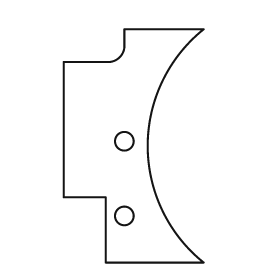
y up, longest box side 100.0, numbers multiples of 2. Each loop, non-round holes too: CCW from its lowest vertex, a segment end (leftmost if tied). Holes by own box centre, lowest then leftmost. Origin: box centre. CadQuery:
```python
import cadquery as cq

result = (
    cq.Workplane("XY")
    .moveTo(-12.0, -50.0)
    .lineTo(30.0, -50.0)
    .threePointArc((6.0, 0.0), (30.0, 50.0))
    .lineTo(-4.0, 50.0)
    .lineTo(-4.0, 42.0)
    .threePointArc((-6.0, 38.0), (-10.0, 36.0))
    .lineTo(-30.0, 36.0)
    .lineTo(-30.0, -22.0)
    .lineTo(-12.0, -22.0)
    .close()
    .moveTo(-4.0, -30.0)
    .circle(4.0)
    .moveTo(-4.0, 2.0)
    .circle(4.0)
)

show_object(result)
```